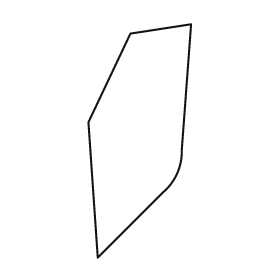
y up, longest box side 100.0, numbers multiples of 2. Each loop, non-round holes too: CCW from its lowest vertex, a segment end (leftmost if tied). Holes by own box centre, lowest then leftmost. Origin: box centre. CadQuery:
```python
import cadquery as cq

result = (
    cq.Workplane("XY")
    .moveTo(-18.0, -50.0)
    .lineTo(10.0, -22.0)
    .threePointArc((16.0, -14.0), (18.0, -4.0))
    .lineTo(22.0, 50.0)
    .lineTo(-4.0, 46.0)
    .lineTo(-22.0, 8.0)
    .close()
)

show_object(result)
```